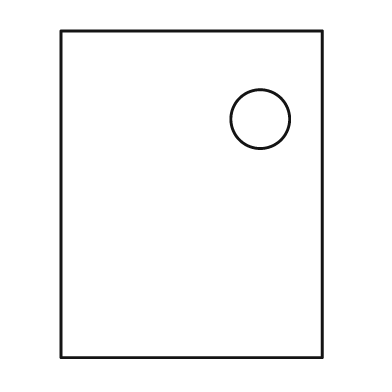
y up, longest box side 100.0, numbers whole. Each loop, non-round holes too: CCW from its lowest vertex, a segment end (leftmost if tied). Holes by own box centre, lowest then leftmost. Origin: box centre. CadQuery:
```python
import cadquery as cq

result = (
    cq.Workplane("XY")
    .moveTo(-40.0, -50.0)
    .lineTo(40.0, -50.0)
    .lineTo(40.0, 50.0)
    .lineTo(-40.0, 50.0)
    .close()
    .moveTo(21.0, 23.0)
    .circle(9.0)
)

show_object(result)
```